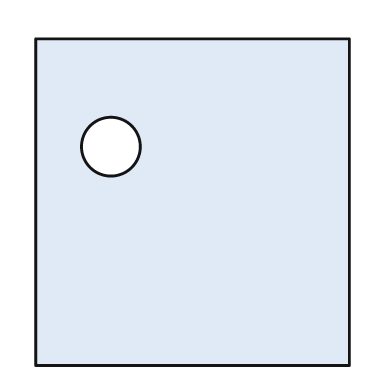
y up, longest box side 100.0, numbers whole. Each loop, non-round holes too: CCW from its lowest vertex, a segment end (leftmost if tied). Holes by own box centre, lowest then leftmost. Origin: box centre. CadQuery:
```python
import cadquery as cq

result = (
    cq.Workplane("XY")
    .moveTo(-48.0, -50.0)
    .lineTo(48.0, -50.0)
    .lineTo(48.0, 50.0)
    .lineTo(-48.0, 50.0)
    .close()
    .moveTo(-25.0, 17.0)
    .circle(9.0)
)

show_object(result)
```